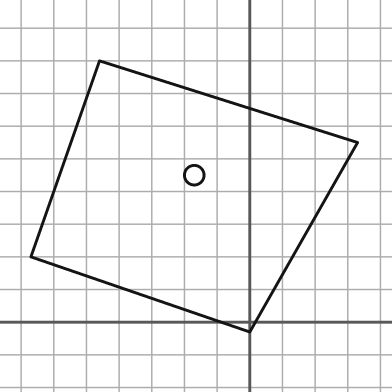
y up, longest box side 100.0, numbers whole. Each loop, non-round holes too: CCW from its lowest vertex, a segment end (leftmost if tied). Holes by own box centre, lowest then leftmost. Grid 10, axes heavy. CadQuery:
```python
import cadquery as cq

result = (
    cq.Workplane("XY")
    .moveTo(0.0, -3.0)
    .lineTo(33.0, 55.0)
    .lineTo(-46.0, 80.0)
    .lineTo(-67.0, 20.0)
    .close()
    .moveTo(-17.0, 45.0)
    .circle(3.0)
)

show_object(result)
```